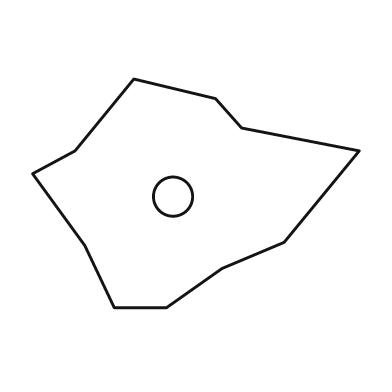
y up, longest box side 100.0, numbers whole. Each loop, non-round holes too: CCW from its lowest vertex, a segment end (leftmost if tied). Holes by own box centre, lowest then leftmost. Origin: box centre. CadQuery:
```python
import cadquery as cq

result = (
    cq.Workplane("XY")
    .moveTo(-25.0, -35.0)
    .lineTo(-9.0, -35.0)
    .lineTo(8.0, -23.0)
    .lineTo(27.0, -15.0)
    .lineTo(50.0, 13.0)
    .lineTo(14.0, 20.0)
    .lineTo(6.0, 29.0)
    .lineTo(-19.0, 35.0)
    .lineTo(-37.0, 13.0)
    .lineTo(-50.0, 6.0)
    .lineTo(-34.0, -16.0)
    .close()
    .moveTo(-7.0, -1.0)
    .circle(6.0)
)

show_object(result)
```